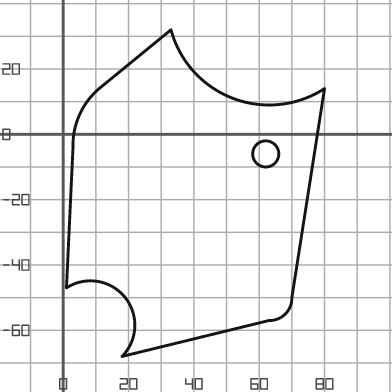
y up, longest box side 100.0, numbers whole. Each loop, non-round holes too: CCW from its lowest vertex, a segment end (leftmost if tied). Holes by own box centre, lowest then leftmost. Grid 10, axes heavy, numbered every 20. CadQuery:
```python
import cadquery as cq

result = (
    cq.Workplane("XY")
    .moveTo(18.0, -68.0)
    .lineTo(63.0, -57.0)
    .threePointArc((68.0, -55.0), (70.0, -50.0))
    .lineTo(80.0, 14.0)
    .threePointArc((52.0, 11.0), (33.0, 32.0))
    .lineTo(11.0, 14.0)
    .threePointArc((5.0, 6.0), (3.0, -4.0))
    .lineTo(1.0, -47.0)
    .threePointArc((19.0, -50.0), (18.0, -68.0))
    .close()
    .moveTo(62.0, -6.0)
    .circle(4.0)
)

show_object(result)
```